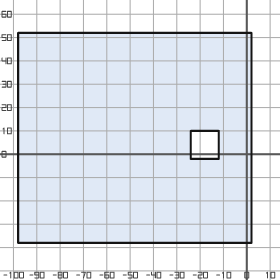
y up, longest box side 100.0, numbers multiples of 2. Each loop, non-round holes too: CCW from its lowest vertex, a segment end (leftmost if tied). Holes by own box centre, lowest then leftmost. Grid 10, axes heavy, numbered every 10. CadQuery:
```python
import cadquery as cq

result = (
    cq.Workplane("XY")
    .moveTo(-98.0, -38.0)
    .lineTo(2.0, -38.0)
    .lineTo(2.0, 52.0)
    .lineTo(-98.0, 52.0)
    .close()
    .moveTo(-24.0, -2.0)
    .lineTo(-12.0, -2.0)
    .lineTo(-12.0, 10.0)
    .lineTo(-24.0, 10.0)
    .close()
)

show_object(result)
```